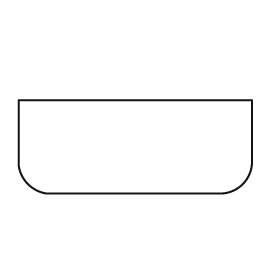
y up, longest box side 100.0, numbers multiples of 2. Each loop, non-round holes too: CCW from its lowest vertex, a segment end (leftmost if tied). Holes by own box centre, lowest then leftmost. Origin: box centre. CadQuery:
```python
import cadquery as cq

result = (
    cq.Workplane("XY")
    .moveTo(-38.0, -20.0)
    .lineTo(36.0, -20.0)
    .threePointArc((46.0, -16.0), (50.0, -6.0))
    .lineTo(50.0, 20.0)
    .lineTo(-50.0, 20.0)
    .lineTo(-50.0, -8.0)
    .threePointArc((-46.0, -16.0), (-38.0, -20.0))
    .close()
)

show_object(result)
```